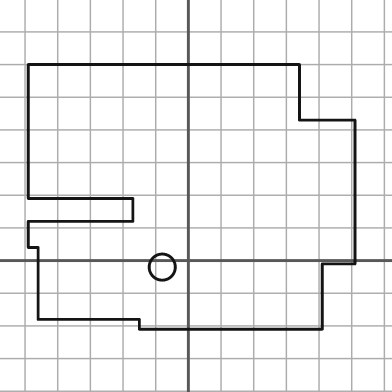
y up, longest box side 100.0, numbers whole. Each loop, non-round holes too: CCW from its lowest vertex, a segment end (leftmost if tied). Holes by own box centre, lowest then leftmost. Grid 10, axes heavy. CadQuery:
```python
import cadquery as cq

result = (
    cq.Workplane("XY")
    .moveTo(-15.0, -21.0)
    .lineTo(41.0, -21.0)
    .lineTo(41.0, -1.0)
    .lineTo(51.0, -1.0)
    .lineTo(51.0, 43.0)
    .lineTo(34.0, 43.0)
    .lineTo(34.0, 60.0)
    .lineTo(-49.0, 60.0)
    .lineTo(-49.0, 19.0)
    .lineTo(-17.0, 19.0)
    .lineTo(-17.0, 12.0)
    .lineTo(-49.0, 12.0)
    .lineTo(-49.0, 4.0)
    .lineTo(-46.0, 4.0)
    .lineTo(-46.0, -18.0)
    .lineTo(-15.0, -18.0)
    .close()
    .moveTo(-8.0, -2.0)
    .circle(4.0)
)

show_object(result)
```